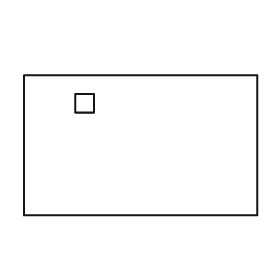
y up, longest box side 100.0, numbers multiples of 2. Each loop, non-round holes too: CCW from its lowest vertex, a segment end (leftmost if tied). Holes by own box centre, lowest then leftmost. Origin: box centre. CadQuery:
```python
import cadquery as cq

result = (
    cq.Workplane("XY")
    .moveTo(-50.0, -30.0)
    .lineTo(50.0, -30.0)
    .lineTo(50.0, 30.0)
    .lineTo(-50.0, 30.0)
    .close()
    .moveTo(-28.0, 14.0)
    .lineTo(-20.0, 14.0)
    .lineTo(-20.0, 22.0)
    .lineTo(-28.0, 22.0)
    .close()
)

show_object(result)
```